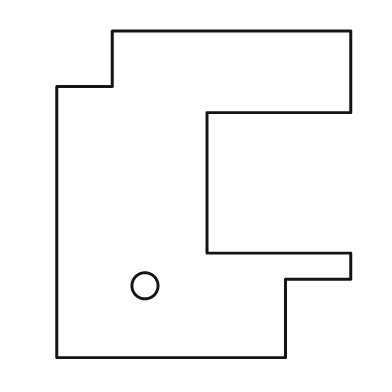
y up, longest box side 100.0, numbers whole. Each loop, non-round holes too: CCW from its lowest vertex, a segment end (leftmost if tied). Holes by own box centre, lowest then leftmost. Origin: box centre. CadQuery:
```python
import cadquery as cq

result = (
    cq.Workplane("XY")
    .moveTo(-45.0, -50.0)
    .lineTo(25.0, -50.0)
    .lineTo(25.0, -26.0)
    .lineTo(45.0, -26.0)
    .lineTo(45.0, -18.0)
    .lineTo(1.0, -18.0)
    .lineTo(1.0, 25.0)
    .lineTo(45.0, 25.0)
    .lineTo(45.0, 50.0)
    .lineTo(-28.0, 50.0)
    .lineTo(-28.0, 33.0)
    .lineTo(-45.0, 33.0)
    .close()
    .moveTo(-18.0, -28.0)
    .circle(4.0)
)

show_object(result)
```